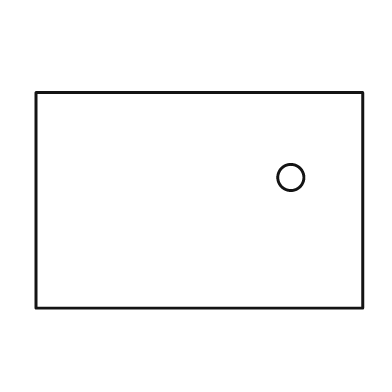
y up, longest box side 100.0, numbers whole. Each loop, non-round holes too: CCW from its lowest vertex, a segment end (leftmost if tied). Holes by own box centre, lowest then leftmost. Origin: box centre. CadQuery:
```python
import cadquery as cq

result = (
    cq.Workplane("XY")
    .moveTo(-50.0, -33.0)
    .lineTo(50.0, -33.0)
    .lineTo(50.0, 33.0)
    .lineTo(-50.0, 33.0)
    .close()
    .moveTo(28.0, 7.0)
    .circle(4.0)
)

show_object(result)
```